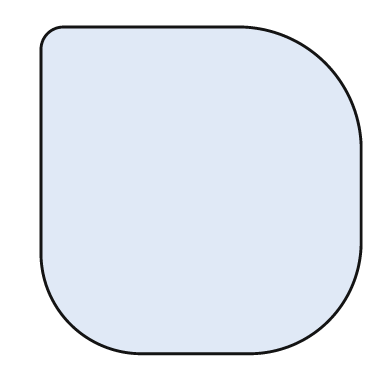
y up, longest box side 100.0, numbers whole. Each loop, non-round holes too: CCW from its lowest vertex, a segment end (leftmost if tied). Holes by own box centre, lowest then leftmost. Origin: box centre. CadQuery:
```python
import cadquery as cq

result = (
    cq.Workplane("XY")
    .moveTo(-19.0, -50.0)
    .lineTo(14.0, -50.0)
    .threePointArc((39.0, -40.0), (49.0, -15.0))
    .lineTo(49.0, 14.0)
    .threePointArc((38.0, 39.0), (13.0, 50.0))
    .lineTo(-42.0, 50.0)
    .threePointArc((-47.0, 48.0), (-49.0, 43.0))
    .lineTo(-49.0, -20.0)
    .threePointArc((-40.0, -41.0), (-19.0, -50.0))
    .close()
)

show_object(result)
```